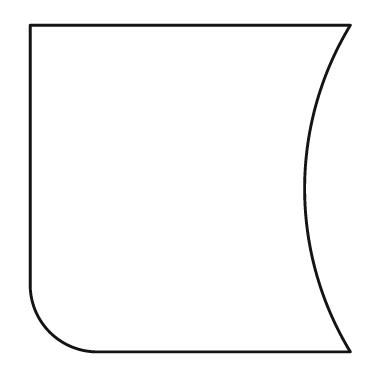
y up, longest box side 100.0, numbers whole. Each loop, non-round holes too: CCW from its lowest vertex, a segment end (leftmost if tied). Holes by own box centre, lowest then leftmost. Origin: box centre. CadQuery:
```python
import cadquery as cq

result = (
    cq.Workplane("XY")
    .moveTo(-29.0, -50.0)
    .lineTo(49.0, -50.0)
    .threePointArc((35.0, 0.0), (49.0, 50.0))
    .lineTo(-49.0, 50.0)
    .lineTo(-49.0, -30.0)
    .threePointArc((-43.0, -44.0), (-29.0, -50.0))
    .close()
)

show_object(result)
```